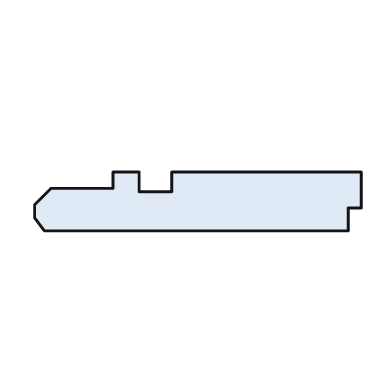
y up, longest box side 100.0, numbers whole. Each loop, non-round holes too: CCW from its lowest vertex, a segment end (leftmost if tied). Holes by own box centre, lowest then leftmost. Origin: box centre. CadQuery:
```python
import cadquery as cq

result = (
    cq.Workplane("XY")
    .moveTo(-47.0, -9.0)
    .lineTo(46.0, -9.0)
    .lineTo(46.0, -2.0)
    .lineTo(50.0, -2.0)
    .lineTo(50.0, 9.0)
    .lineTo(-8.0, 9.0)
    .lineTo(-8.0, 3.0)
    .lineTo(-18.0, 3.0)
    .lineTo(-18.0, 9.0)
    .lineTo(-26.0, 9.0)
    .lineTo(-26.0, 4.0)
    .lineTo(-45.0, 4.0)
    .lineTo(-50.0, -1.0)
    .lineTo(-50.0, -5.0)
    .close()
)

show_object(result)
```